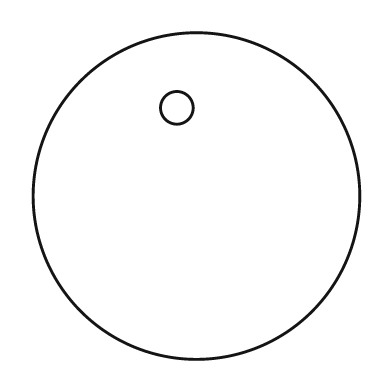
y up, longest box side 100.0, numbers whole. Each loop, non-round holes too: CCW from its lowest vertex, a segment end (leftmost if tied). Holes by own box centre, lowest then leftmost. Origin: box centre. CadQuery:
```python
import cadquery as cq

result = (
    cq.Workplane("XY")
    .moveTo(0.0, 0.0)
    .circle(50.0)
    .moveTo(-6.0, 27.0)
    .circle(5.0)
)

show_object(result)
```